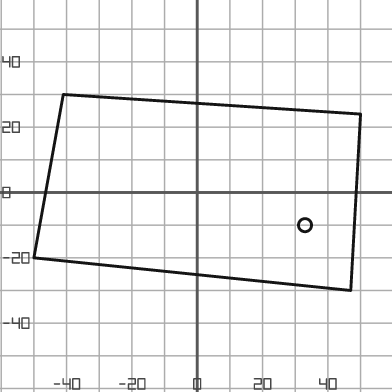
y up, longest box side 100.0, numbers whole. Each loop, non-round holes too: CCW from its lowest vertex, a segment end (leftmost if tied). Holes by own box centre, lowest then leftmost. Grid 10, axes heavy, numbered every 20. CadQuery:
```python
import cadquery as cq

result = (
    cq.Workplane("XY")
    .moveTo(47.0, -30.0)
    .lineTo(50.0, 24.0)
    .lineTo(-41.0, 30.0)
    .lineTo(-50.0, -20.0)
    .close()
    .moveTo(33.0, -10.0)
    .circle(2.0)
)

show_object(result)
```